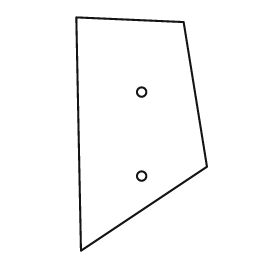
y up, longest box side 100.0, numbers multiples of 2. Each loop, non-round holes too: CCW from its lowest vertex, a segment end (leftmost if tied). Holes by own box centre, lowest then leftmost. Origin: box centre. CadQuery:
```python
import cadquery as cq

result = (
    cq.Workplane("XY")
    .moveTo(-26.0, -50.0)
    .lineTo(28.0, -14.0)
    .lineTo(18.0, 48.0)
    .lineTo(-28.0, 50.0)
    .close()
    .moveTo(0.0, -18.0)
    .circle(2.0)
    .moveTo(0.0, 18.0)
    .circle(2.0)
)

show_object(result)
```